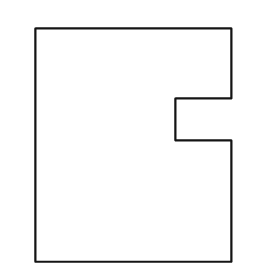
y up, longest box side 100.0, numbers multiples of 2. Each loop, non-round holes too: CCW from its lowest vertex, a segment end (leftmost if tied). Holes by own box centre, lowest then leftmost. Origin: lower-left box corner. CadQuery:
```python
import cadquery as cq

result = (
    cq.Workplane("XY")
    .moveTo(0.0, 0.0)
    .lineTo(84.0, 0.0)
    .lineTo(84.0, 52.0)
    .lineTo(60.0, 52.0)
    .lineTo(60.0, 70.0)
    .lineTo(84.0, 70.0)
    .lineTo(84.0, 100.0)
    .lineTo(0.0, 100.0)
    .close()
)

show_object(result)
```